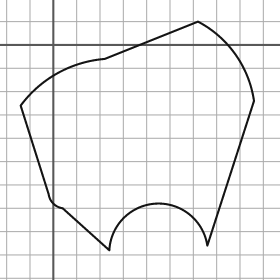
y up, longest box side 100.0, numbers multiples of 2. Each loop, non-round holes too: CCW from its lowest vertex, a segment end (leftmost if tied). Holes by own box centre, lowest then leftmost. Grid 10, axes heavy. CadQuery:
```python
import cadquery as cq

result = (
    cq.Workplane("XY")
    .moveTo(24.0, -88.0)
    .threePointArc((44.0, -68.0), (66.0, -86.0))
    .lineTo(86.0, -24.0)
    .threePointArc((78.0, -4.0), (62.0, 10.0))
    .lineTo(22.0, -6.0)
    .threePointArc((2.0, -12.0), (-14.0, -26.0))
    .lineTo(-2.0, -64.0)
    .threePointArc((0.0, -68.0), (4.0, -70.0))
    .close()
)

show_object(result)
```